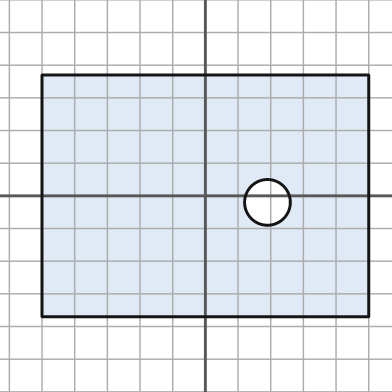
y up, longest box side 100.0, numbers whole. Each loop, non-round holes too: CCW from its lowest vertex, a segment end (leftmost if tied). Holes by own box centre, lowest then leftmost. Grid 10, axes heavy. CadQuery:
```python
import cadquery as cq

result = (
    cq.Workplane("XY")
    .moveTo(-50.0, -37.0)
    .lineTo(50.0, -37.0)
    .lineTo(50.0, 37.0)
    .lineTo(-50.0, 37.0)
    .close()
    .moveTo(19.0, -2.0)
    .circle(7.0)
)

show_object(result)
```